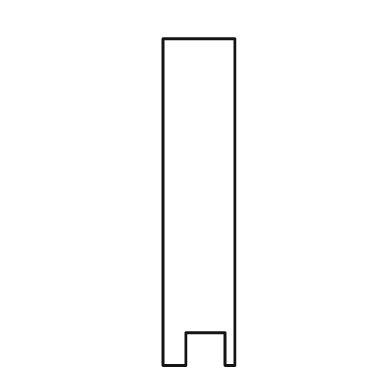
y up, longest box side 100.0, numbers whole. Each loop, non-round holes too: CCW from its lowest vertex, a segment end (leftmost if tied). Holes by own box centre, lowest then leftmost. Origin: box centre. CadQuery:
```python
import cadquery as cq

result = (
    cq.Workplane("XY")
    .moveTo(-11.0, -50.0)
    .lineTo(-4.0, -50.0)
    .lineTo(-4.0, -40.0)
    .lineTo(8.0, -40.0)
    .lineTo(8.0, -50.0)
    .lineTo(11.0, -50.0)
    .lineTo(11.0, 50.0)
    .lineTo(-11.0, 50.0)
    .close()
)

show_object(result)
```